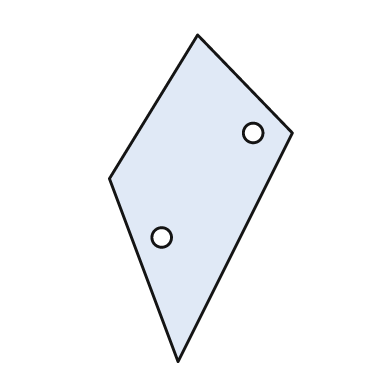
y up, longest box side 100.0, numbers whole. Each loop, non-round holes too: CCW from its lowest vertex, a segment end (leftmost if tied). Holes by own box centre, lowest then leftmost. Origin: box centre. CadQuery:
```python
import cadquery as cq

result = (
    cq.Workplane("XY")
    .moveTo(-7.0, -50.0)
    .lineTo(28.0, 20.0)
    .lineTo(-1.0, 50.0)
    .lineTo(-28.0, 6.0)
    .close()
    .moveTo(-12.0, -12.0)
    .circle(3.0)
    .moveTo(16.0, 20.0)
    .circle(3.0)
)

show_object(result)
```